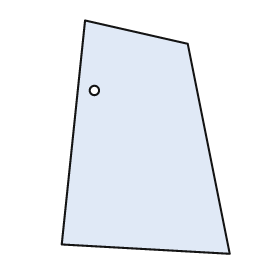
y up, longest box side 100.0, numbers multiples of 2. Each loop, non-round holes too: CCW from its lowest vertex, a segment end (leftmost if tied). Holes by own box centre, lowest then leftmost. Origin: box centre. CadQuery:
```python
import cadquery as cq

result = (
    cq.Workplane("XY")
    .moveTo(36.0, -50.0)
    .lineTo(18.0, 40.0)
    .lineTo(-26.0, 50.0)
    .lineTo(-36.0, -46.0)
    .close()
    .moveTo(-22.0, 20.0)
    .circle(2.0)
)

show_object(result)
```